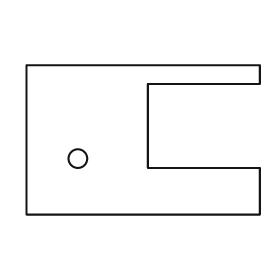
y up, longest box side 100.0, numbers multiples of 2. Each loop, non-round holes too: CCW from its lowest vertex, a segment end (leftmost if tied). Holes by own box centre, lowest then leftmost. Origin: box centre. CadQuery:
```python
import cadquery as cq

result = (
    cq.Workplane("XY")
    .moveTo(-50.0, -32.0)
    .lineTo(50.0, -32.0)
    .lineTo(50.0, -12.0)
    .lineTo(2.0, -12.0)
    .lineTo(2.0, 24.0)
    .lineTo(50.0, 24.0)
    .lineTo(50.0, 32.0)
    .lineTo(-50.0, 32.0)
    .close()
    .moveTo(-28.0, -8.0)
    .circle(4.0)
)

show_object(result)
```